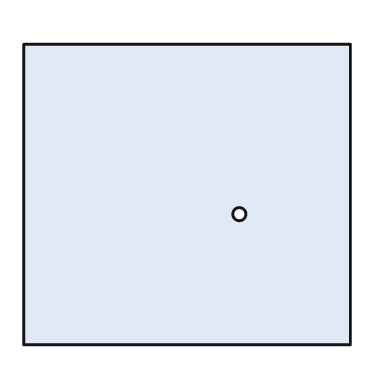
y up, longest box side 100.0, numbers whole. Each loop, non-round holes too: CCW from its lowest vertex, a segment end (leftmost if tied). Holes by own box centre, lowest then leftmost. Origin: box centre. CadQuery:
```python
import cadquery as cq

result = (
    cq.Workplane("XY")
    .moveTo(-50.0, -46.0)
    .lineTo(50.0, -46.0)
    .lineTo(50.0, 46.0)
    .lineTo(-50.0, 46.0)
    .close()
    .moveTo(16.0, -6.0)
    .circle(2.0)
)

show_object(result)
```